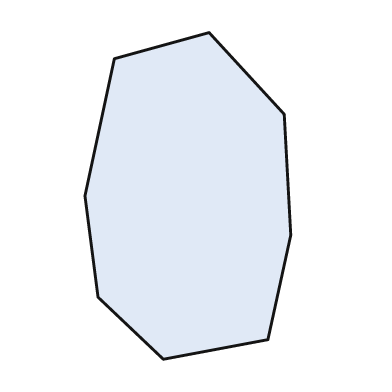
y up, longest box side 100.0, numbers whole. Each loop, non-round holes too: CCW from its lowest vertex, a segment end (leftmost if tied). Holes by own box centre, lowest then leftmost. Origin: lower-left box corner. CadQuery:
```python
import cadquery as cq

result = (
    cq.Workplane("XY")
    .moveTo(24.0, 0.0)
    .lineTo(56.0, 6.0)
    .lineTo(63.0, 38.0)
    .lineTo(61.0, 75.0)
    .lineTo(38.0, 100.0)
    .lineTo(9.0, 92.0)
    .lineTo(0.0, 50.0)
    .lineTo(4.0, 19.0)
    .close()
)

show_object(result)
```